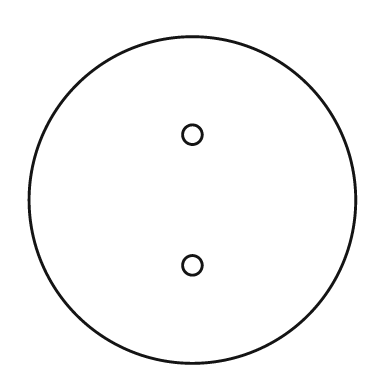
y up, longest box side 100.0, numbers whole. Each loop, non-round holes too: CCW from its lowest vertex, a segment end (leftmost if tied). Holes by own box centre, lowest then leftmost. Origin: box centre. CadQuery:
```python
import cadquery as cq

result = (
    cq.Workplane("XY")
    .moveTo(0.0, 0.0)
    .circle(50.0)
    .moveTo(0.0, -20.0)
    .circle(3.0)
    .moveTo(0.0, 20.0)
    .circle(3.0)
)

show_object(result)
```